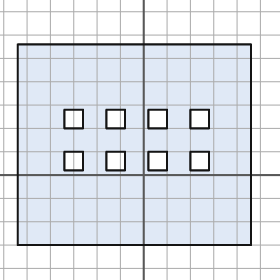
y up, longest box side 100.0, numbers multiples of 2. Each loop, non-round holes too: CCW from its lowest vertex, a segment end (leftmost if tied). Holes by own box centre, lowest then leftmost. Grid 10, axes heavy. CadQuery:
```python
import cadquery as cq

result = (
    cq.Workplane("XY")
    .moveTo(-54.0, -30.0)
    .lineTo(46.0, -30.0)
    .lineTo(46.0, 56.0)
    .lineTo(-54.0, 56.0)
    .close()
    .moveTo(-34.0, 2.0)
    .lineTo(-26.0, 2.0)
    .lineTo(-26.0, 10.0)
    .lineTo(-34.0, 10.0)
    .close()
    .moveTo(-16.0, 2.0)
    .lineTo(-8.0, 2.0)
    .lineTo(-8.0, 10.0)
    .lineTo(-16.0, 10.0)
    .close()
    .moveTo(2.0, 2.0)
    .lineTo(10.0, 2.0)
    .lineTo(10.0, 10.0)
    .lineTo(2.0, 10.0)
    .close()
    .moveTo(20.0, 2.0)
    .lineTo(28.0, 2.0)
    .lineTo(28.0, 10.0)
    .lineTo(20.0, 10.0)
    .close()
    .moveTo(-34.0, 20.0)
    .lineTo(-26.0, 20.0)
    .lineTo(-26.0, 28.0)
    .lineTo(-34.0, 28.0)
    .close()
    .moveTo(-16.0, 20.0)
    .lineTo(-8.0, 20.0)
    .lineTo(-8.0, 28.0)
    .lineTo(-16.0, 28.0)
    .close()
    .moveTo(2.0, 20.0)
    .lineTo(10.0, 20.0)
    .lineTo(10.0, 28.0)
    .lineTo(2.0, 28.0)
    .close()
    .moveTo(20.0, 20.0)
    .lineTo(28.0, 20.0)
    .lineTo(28.0, 28.0)
    .lineTo(20.0, 28.0)
    .close()
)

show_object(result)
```